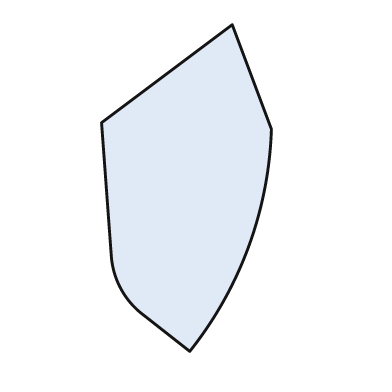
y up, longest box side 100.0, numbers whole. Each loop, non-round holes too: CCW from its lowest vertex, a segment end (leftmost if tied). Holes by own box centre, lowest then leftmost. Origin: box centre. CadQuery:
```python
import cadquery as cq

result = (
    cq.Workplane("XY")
    .moveTo(1.0, -50.0)
    .threePointArc((19.0, -18.0), (26.0, 18.0))
    .lineTo(14.0, 50.0)
    .lineTo(-26.0, 20.0)
    .lineTo(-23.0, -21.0)
    .threePointArc((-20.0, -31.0), (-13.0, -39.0))
    .close()
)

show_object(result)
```